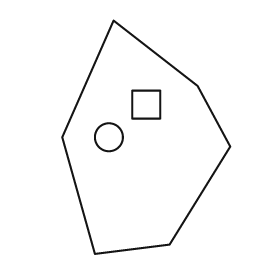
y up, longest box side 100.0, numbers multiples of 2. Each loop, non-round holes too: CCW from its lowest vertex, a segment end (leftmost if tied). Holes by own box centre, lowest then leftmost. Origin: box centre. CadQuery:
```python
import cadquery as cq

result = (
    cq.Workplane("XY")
    .moveTo(-22.0, -50.0)
    .lineTo(10.0, -46.0)
    .lineTo(36.0, -4.0)
    .lineTo(22.0, 22.0)
    .lineTo(-14.0, 50.0)
    .lineTo(-36.0, 0.0)
    .close()
    .moveTo(-16.0, 0.0)
    .circle(6.0)
    .moveTo(-6.0, 8.0)
    .lineTo(6.0, 8.0)
    .lineTo(6.0, 20.0)
    .lineTo(-6.0, 20.0)
    .close()
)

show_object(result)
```